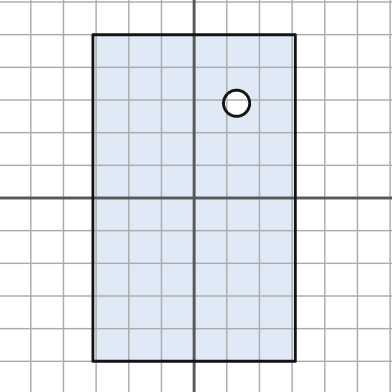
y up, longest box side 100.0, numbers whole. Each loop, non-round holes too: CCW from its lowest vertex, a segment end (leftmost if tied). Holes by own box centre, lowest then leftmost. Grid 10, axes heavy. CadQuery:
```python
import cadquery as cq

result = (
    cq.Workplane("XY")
    .moveTo(-31.0, -50.0)
    .lineTo(31.0, -50.0)
    .lineTo(31.0, 50.0)
    .lineTo(-31.0, 50.0)
    .close()
    .moveTo(13.0, 29.0)
    .circle(4.0)
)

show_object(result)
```